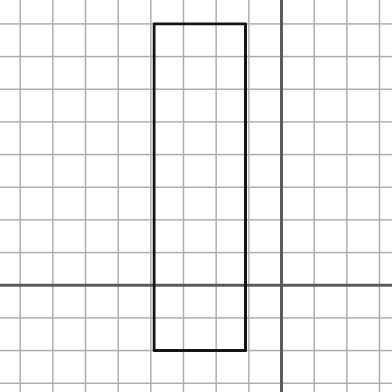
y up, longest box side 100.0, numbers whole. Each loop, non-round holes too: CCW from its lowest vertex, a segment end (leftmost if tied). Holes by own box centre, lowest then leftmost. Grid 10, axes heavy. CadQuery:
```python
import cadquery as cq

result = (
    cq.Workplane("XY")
    .moveTo(-39.0, -20.0)
    .lineTo(-11.0, -20.0)
    .lineTo(-11.0, 80.0)
    .lineTo(-39.0, 80.0)
    .close()
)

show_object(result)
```